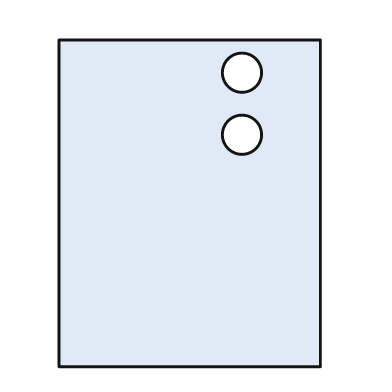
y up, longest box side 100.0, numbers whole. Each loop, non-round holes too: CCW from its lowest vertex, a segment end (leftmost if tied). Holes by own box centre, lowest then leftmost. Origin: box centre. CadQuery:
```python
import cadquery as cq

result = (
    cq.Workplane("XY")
    .moveTo(-40.0, -50.0)
    .lineTo(40.0, -50.0)
    .lineTo(40.0, 50.0)
    .lineTo(-40.0, 50.0)
    .close()
    .moveTo(16.0, 21.0)
    .circle(6.0)
    .moveTo(16.0, 40.0)
    .circle(6.0)
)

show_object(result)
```